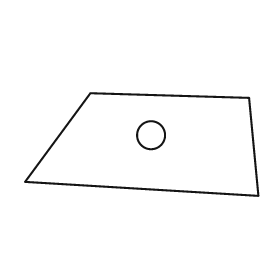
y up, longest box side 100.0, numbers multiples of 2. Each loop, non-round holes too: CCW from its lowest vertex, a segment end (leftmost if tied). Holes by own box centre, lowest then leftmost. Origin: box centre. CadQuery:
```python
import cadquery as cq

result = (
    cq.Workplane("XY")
    .moveTo(50.0, -22.0)
    .lineTo(46.0, 20.0)
    .lineTo(-22.0, 22.0)
    .lineTo(-50.0, -16.0)
    .close()
    .moveTo(4.0, 4.0)
    .circle(6.0)
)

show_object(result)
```